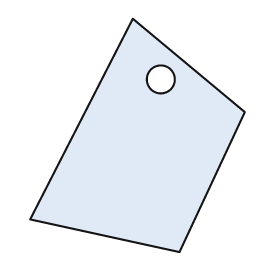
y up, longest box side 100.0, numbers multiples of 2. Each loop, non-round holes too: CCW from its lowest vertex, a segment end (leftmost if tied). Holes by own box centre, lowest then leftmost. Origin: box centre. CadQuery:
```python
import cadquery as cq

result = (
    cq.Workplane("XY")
    .moveTo(18.0, -50.0)
    .lineTo(46.0, 10.0)
    .lineTo(-2.0, 50.0)
    .lineTo(-46.0, -36.0)
    .close()
    .moveTo(10.0, 24.0)
    .circle(6.0)
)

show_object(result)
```